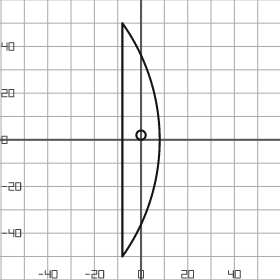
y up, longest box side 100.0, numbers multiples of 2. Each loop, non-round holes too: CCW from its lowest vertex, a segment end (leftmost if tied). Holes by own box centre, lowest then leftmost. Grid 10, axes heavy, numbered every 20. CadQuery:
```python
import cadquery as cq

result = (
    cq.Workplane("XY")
    .moveTo(-8.0, -50.0)
    .threePointArc((8.0, 0.0), (-8.0, 50.0))
    .close()
    .moveTo(0.0, 2.0)
    .circle(2.0)
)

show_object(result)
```